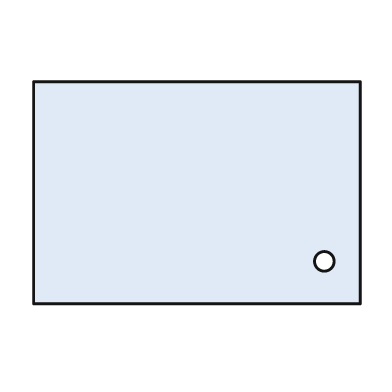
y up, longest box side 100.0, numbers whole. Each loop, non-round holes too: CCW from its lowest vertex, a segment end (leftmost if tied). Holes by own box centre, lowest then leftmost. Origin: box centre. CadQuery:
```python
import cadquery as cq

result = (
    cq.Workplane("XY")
    .moveTo(-50.0, -34.0)
    .lineTo(50.0, -34.0)
    .lineTo(50.0, 34.0)
    .lineTo(-50.0, 34.0)
    .close()
    .moveTo(39.0, -21.0)
    .circle(3.0)
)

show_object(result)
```